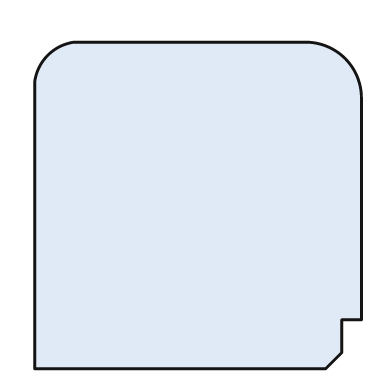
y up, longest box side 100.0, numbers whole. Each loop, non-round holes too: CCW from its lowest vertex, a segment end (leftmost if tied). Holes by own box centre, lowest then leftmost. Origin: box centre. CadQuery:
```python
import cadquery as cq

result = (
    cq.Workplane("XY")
    .moveTo(-50.0, -50.0)
    .lineTo(39.0, -50.0)
    .lineTo(44.0, -45.0)
    .lineTo(44.0, -35.0)
    .lineTo(50.0, -35.0)
    .lineTo(50.0, 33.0)
    .threePointArc((45.0, 45.0), (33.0, 50.0))
    .lineTo(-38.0, 50.0)
    .threePointArc((-46.0, 46.0), (-50.0, 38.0))
    .close()
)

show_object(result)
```